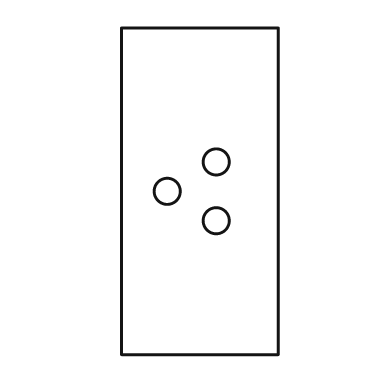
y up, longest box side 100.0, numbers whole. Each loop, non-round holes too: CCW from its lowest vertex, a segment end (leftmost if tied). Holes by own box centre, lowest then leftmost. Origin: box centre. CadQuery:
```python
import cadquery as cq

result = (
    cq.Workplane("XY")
    .moveTo(-24.0, -50.0)
    .lineTo(24.0, -50.0)
    .lineTo(24.0, 50.0)
    .lineTo(-24.0, 50.0)
    .close()
    .moveTo(5.0, -9.0)
    .circle(4.0)
    .moveTo(-10.0, 0.0)
    .circle(4.0)
    .moveTo(5.0, 9.0)
    .circle(4.0)
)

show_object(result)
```